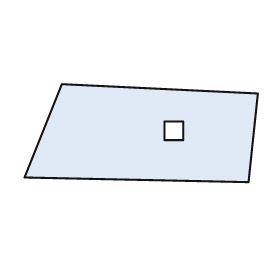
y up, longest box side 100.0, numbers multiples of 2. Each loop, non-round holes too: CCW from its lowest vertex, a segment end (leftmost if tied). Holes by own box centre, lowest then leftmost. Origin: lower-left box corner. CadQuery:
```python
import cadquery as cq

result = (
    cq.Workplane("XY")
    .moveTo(96.0, 0.0)
    .lineTo(100.0, 38.0)
    .lineTo(16.0, 42.0)
    .lineTo(0.0, 2.0)
    .close()
    .moveTo(60.0, 18.0)
    .lineTo(68.0, 18.0)
    .lineTo(68.0, 26.0)
    .lineTo(60.0, 26.0)
    .close()
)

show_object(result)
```